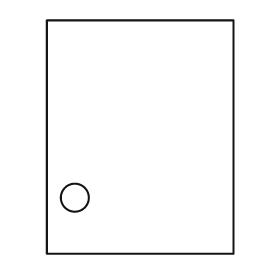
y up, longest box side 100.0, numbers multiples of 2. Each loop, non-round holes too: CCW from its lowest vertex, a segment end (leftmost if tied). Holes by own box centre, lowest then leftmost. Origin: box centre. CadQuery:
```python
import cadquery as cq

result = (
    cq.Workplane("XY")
    .moveTo(-40.0, -50.0)
    .lineTo(40.0, -50.0)
    .lineTo(40.0, 50.0)
    .lineTo(-40.0, 50.0)
    .close()
    .moveTo(-28.0, -26.0)
    .circle(6.0)
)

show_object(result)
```